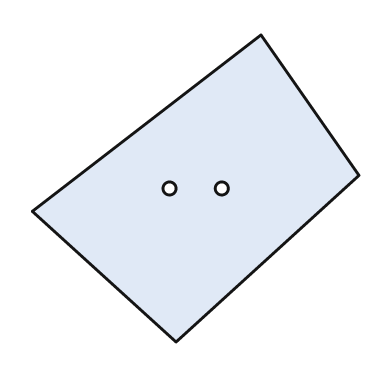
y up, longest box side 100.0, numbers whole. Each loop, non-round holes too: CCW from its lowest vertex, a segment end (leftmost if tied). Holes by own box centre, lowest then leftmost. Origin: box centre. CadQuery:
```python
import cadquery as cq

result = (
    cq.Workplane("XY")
    .moveTo(-6.0, -47.0)
    .lineTo(50.0, 4.0)
    .lineTo(20.0, 47.0)
    .lineTo(-50.0, -7.0)
    .close()
    .moveTo(-8.0, 0.0)
    .circle(2.0)
    .moveTo(8.0, 0.0)
    .circle(2.0)
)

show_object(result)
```